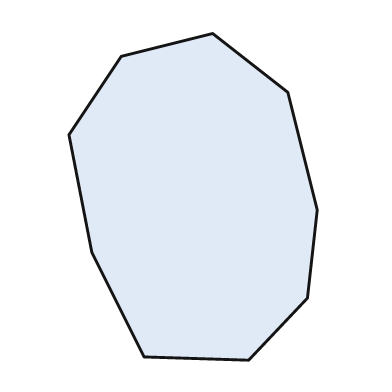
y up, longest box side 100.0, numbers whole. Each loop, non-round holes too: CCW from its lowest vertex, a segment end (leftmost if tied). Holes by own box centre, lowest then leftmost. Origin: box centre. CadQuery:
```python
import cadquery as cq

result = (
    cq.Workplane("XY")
    .moveTo(17.0, -50.0)
    .lineTo(35.0, -31.0)
    .lineTo(38.0, -4.0)
    .lineTo(29.0, 32.0)
    .lineTo(6.0, 50.0)
    .lineTo(-22.0, 43.0)
    .lineTo(-38.0, 19.0)
    .lineTo(-31.0, -17.0)
    .lineTo(-15.0, -49.0)
    .close()
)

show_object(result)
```